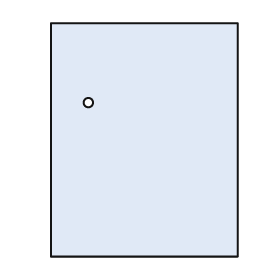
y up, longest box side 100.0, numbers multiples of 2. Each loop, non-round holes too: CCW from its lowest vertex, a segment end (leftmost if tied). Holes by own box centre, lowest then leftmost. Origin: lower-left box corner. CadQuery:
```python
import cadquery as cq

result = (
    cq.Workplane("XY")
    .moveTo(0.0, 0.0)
    .lineTo(80.0, 0.0)
    .lineTo(80.0, 100.0)
    .lineTo(0.0, 100.0)
    .close()
    .moveTo(16.0, 66.0)
    .circle(2.0)
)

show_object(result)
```